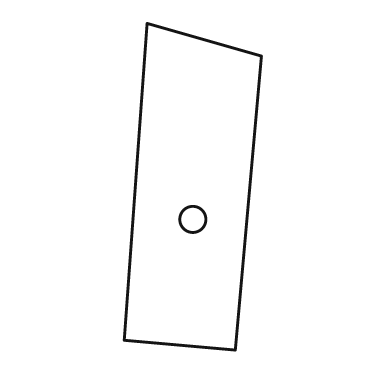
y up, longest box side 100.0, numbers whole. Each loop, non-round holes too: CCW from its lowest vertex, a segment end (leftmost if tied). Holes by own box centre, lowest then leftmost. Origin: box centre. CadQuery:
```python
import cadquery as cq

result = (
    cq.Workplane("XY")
    .moveTo(13.0, -50.0)
    .lineTo(21.0, 40.0)
    .lineTo(-14.0, 50.0)
    .lineTo(-21.0, -47.0)
    .close()
    .moveTo(0.0, -10.0)
    .circle(4.0)
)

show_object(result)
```